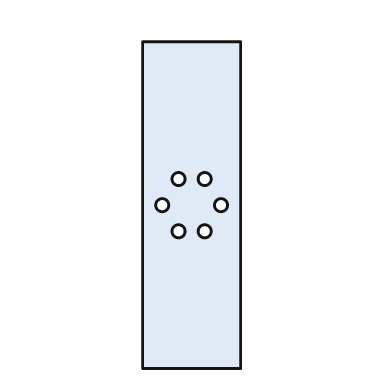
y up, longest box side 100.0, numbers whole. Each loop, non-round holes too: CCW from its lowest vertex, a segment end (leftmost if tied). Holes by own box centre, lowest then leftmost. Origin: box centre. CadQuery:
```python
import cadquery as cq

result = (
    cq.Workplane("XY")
    .moveTo(-15.0, -50.0)
    .lineTo(15.0, -50.0)
    .lineTo(15.0, 50.0)
    .lineTo(-15.0, 50.0)
    .close()
    .moveTo(-4.0, -8.0)
    .circle(2.0)
    .moveTo(4.0, -8.0)
    .circle(2.0)
    .moveTo(-9.0, 0.0)
    .circle(2.0)
    .moveTo(9.0, 0.0)
    .circle(2.0)
    .moveTo(-4.0, 8.0)
    .circle(2.0)
    .moveTo(4.0, 8.0)
    .circle(2.0)
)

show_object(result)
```